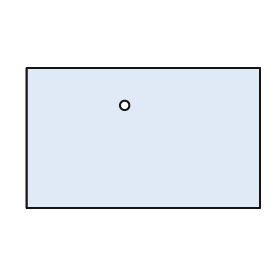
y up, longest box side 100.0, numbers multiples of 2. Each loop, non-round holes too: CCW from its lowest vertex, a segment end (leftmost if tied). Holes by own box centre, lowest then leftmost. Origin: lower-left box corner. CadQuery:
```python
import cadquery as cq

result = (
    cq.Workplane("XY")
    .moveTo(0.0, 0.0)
    .lineTo(100.0, 0.0)
    .lineTo(100.0, 60.0)
    .lineTo(0.0, 60.0)
    .close()
    .moveTo(42.0, 44.0)
    .circle(2.0)
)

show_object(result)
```